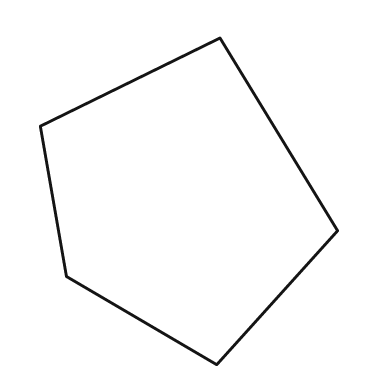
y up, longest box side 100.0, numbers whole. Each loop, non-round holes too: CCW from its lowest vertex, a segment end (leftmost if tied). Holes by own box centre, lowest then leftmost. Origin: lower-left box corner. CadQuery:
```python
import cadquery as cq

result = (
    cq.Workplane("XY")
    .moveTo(54.0, 0.0)
    .lineTo(91.0, 41.0)
    .lineTo(55.0, 100.0)
    .lineTo(0.0, 73.0)
    .lineTo(8.0, 27.0)
    .close()
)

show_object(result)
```